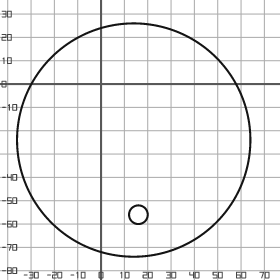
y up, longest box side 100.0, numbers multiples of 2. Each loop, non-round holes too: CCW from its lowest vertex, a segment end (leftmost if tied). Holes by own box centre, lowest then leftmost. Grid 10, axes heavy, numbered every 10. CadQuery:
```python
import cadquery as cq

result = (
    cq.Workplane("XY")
    .moveTo(14.0, -24.0)
    .circle(50.0)
    .moveTo(16.0, -56.0)
    .circle(4.0)
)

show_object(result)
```